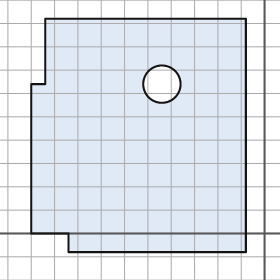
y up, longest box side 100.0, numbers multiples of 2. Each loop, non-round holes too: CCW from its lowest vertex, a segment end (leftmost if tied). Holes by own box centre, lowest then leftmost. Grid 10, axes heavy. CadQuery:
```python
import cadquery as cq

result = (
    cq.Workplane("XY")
    .moveTo(-84.0, -8.0)
    .lineTo(-8.0, -8.0)
    .lineTo(-8.0, 92.0)
    .lineTo(-94.0, 92.0)
    .lineTo(-94.0, 64.0)
    .lineTo(-100.0, 64.0)
    .lineTo(-100.0, 0.0)
    .lineTo(-84.0, 0.0)
    .close()
    .moveTo(-44.0, 64.0)
    .circle(8.0)
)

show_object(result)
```